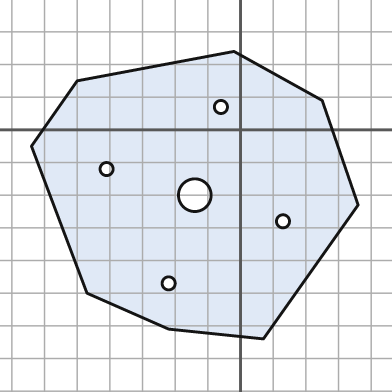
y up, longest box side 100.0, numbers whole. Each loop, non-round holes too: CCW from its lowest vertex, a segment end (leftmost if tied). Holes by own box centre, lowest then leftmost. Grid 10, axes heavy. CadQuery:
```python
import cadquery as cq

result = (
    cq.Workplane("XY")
    .moveTo(7.0, -64.0)
    .lineTo(36.0, -23.0)
    .lineTo(25.0, 9.0)
    .lineTo(-2.0, 24.0)
    .lineTo(-50.0, 15.0)
    .lineTo(-64.0, -5.0)
    .lineTo(-47.0, -50.0)
    .lineTo(-22.0, -61.0)
    .close()
    .moveTo(-22.0, -47.0)
    .circle(2.0)
    .moveTo(13.0, -28.0)
    .circle(2.0)
    .moveTo(-14.0, -20.0)
    .circle(5.0)
    .moveTo(-41.0, -12.0)
    .circle(2.0)
    .moveTo(-6.0, 7.0)
    .circle(2.0)
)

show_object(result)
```